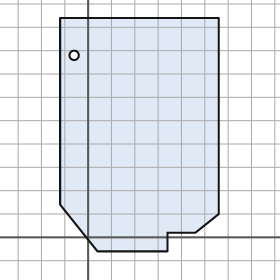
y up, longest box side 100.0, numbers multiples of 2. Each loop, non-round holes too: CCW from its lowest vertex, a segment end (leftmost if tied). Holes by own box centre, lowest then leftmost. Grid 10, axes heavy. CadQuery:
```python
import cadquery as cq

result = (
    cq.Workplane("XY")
    .moveTo(4.0, -6.0)
    .lineTo(34.0, -6.0)
    .lineTo(34.0, 2.0)
    .lineTo(46.0, 2.0)
    .lineTo(56.0, 10.0)
    .lineTo(56.0, 94.0)
    .lineTo(-12.0, 94.0)
    .lineTo(-12.0, 14.0)
    .close()
    .moveTo(-6.0, 78.0)
    .circle(2.0)
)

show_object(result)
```